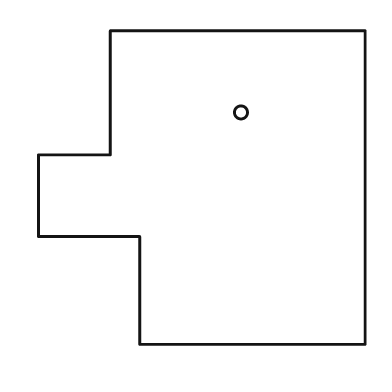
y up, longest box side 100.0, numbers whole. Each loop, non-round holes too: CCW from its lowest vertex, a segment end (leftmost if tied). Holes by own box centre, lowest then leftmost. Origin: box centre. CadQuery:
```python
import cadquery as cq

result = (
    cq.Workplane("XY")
    .moveTo(-19.0, -48.0)
    .lineTo(50.0, -48.0)
    .lineTo(50.0, 48.0)
    .lineTo(-28.0, 48.0)
    .lineTo(-28.0, 10.0)
    .lineTo(-50.0, 10.0)
    .lineTo(-50.0, -15.0)
    .lineTo(-19.0, -15.0)
    .close()
    .moveTo(12.0, 23.0)
    .circle(2.0)
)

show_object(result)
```